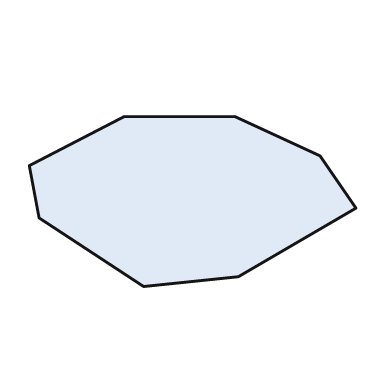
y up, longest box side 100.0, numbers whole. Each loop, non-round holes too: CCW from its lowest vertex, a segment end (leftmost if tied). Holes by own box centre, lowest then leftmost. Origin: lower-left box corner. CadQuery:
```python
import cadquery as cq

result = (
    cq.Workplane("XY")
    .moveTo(35.0, 0.0)
    .lineTo(64.0, 3.0)
    .lineTo(100.0, 24.0)
    .lineTo(89.0, 40.0)
    .lineTo(63.0, 52.0)
    .lineTo(29.0, 52.0)
    .lineTo(0.0, 37.0)
    .lineTo(3.0, 21.0)
    .close()
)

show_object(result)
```